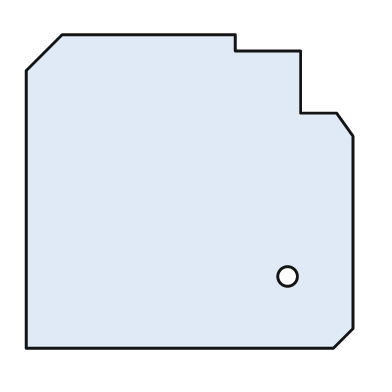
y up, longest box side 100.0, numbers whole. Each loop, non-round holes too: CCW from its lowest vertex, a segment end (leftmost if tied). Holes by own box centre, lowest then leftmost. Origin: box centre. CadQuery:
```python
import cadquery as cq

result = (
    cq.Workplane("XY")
    .moveTo(-50.0, -48.0)
    .lineTo(44.0, -48.0)
    .lineTo(50.0, -42.0)
    .lineTo(50.0, 17.0)
    .lineTo(45.0, 24.0)
    .lineTo(34.0, 24.0)
    .lineTo(34.0, 43.0)
    .lineTo(14.0, 43.0)
    .lineTo(14.0, 48.0)
    .lineTo(-39.0, 48.0)
    .lineTo(-50.0, 37.0)
    .close()
    .moveTo(30.0, -26.0)
    .circle(3.0)
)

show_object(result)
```